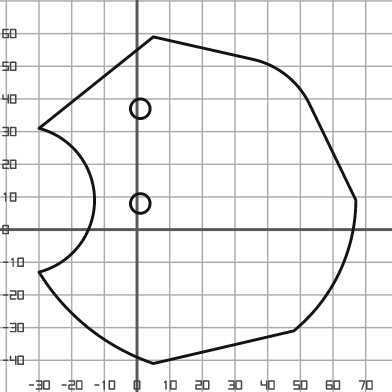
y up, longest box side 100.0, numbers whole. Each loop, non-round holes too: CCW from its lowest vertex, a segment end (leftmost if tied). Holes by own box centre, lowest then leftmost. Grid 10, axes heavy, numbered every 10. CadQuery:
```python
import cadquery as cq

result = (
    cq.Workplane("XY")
    .moveTo(5.0, -41.0)
    .lineTo(48.0, -31.0)
    .threePointArc((62.0, -13.0), (67.0, 9.0))
    .lineTo(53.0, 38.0)
    .threePointArc((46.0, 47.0), (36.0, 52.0))
    .lineTo(5.0, 59.0)
    .lineTo(-30.0, 31.0)
    .threePointArc((-13.0, 9.0), (-30.0, -13.0))
    .threePointArc((-15.0, -30.0), (5.0, -41.0))
    .close()
    .moveTo(1.0, 8.0)
    .circle(3.0)
    .moveTo(1.0, 37.0)
    .circle(3.0)
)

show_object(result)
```